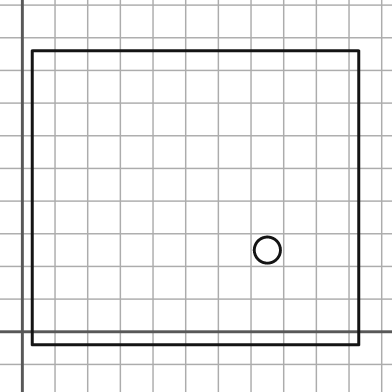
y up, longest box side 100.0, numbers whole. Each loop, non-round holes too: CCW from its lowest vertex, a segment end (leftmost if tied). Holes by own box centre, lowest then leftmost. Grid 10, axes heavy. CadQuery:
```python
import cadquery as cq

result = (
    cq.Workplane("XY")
    .moveTo(3.0, -4.0)
    .lineTo(103.0, -4.0)
    .lineTo(103.0, 86.0)
    .lineTo(3.0, 86.0)
    .close()
    .moveTo(75.0, 25.0)
    .circle(4.0)
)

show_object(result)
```